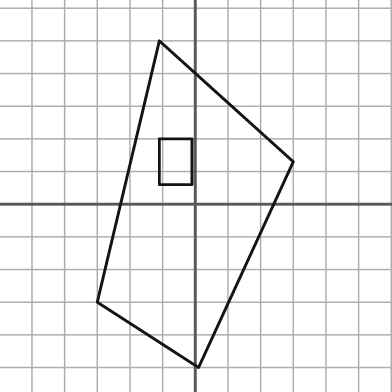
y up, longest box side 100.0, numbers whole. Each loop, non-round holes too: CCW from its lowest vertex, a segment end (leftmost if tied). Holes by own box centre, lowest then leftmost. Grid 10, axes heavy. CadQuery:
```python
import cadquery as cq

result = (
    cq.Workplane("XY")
    .moveTo(1.0, -50.0)
    .lineTo(30.0, 13.0)
    .lineTo(-11.0, 50.0)
    .lineTo(-30.0, -30.0)
    .close()
    .moveTo(-11.0, 6.0)
    .lineTo(-1.0, 6.0)
    .lineTo(-1.0, 20.0)
    .lineTo(-11.0, 20.0)
    .close()
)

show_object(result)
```